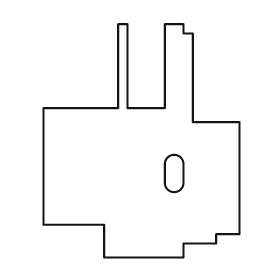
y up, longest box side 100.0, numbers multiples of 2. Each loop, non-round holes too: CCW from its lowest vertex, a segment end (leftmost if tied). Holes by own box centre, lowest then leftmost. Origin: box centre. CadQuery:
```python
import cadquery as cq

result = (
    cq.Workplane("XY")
    .moveTo(-16.0, -50.0)
    .lineTo(18.0, -50.0)
    .lineTo(18.0, -44.0)
    .lineTo(32.0, -44.0)
    .lineTo(32.0, -40.0)
    .lineTo(42.0, -40.0)
    .lineTo(42.0, 8.0)
    .lineTo(22.0, 8.0)
    .lineTo(22.0, 46.0)
    .lineTo(18.0, 46.0)
    .lineTo(18.0, 50.0)
    .lineTo(10.0, 50.0)
    .lineTo(10.0, 14.0)
    .lineTo(-6.0, 14.0)
    .lineTo(-6.0, 50.0)
    .lineTo(-10.0, 50.0)
    .lineTo(-10.0, 14.0)
    .lineTo(-42.0, 14.0)
    .lineTo(-42.0, -36.0)
    .lineTo(-16.0, -36.0)
    .close()
    .moveTo(10.0, -18.0)
    .threePointArc((14.0, -22.0), (18.0, -18.0))
    .lineTo(18.0, -10.0)
    .threePointArc((14.0, -6.0), (10.0, -10.0))
    .close()
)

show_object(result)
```